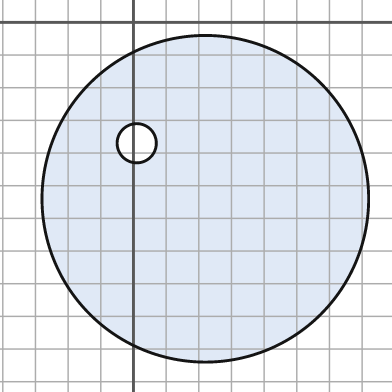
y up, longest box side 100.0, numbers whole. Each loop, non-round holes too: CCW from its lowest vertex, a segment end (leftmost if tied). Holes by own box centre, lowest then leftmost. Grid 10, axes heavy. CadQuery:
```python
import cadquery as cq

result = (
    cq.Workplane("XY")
    .moveTo(22.0, -54.0)
    .circle(50.0)
    .moveTo(1.0, -37.0)
    .circle(6.0)
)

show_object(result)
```